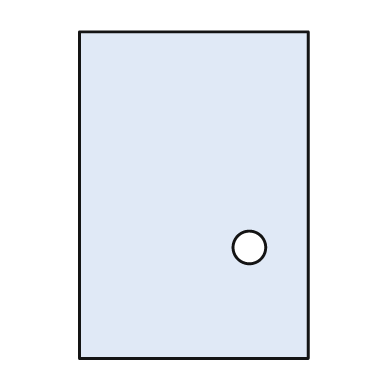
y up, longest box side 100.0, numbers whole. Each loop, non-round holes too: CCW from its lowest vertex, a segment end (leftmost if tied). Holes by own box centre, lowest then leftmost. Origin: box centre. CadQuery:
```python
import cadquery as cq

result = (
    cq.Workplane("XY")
    .moveTo(-35.0, -50.0)
    .lineTo(35.0, -50.0)
    .lineTo(35.0, 50.0)
    .lineTo(-35.0, 50.0)
    .close()
    .moveTo(17.0, -16.0)
    .circle(5.0)
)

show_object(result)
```